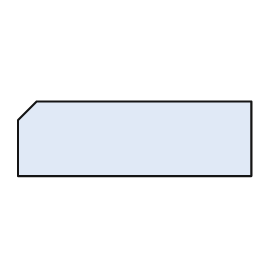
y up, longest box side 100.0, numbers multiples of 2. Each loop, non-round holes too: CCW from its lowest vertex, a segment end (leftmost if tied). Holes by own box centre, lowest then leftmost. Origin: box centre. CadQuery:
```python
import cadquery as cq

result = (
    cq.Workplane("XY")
    .moveTo(-50.0, -16.0)
    .lineTo(50.0, -16.0)
    .lineTo(50.0, 16.0)
    .lineTo(-42.0, 16.0)
    .lineTo(-50.0, 8.0)
    .close()
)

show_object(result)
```